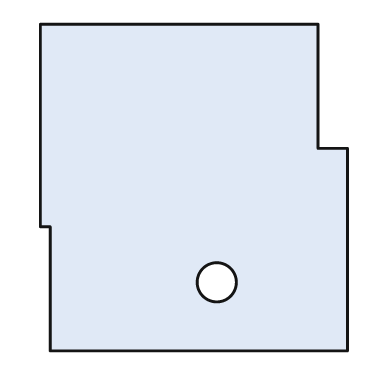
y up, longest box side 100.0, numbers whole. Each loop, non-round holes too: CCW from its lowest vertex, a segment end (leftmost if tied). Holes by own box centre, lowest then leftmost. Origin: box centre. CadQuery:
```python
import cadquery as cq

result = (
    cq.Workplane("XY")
    .moveTo(-44.0, -50.0)
    .lineTo(47.0, -50.0)
    .lineTo(47.0, 12.0)
    .lineTo(38.0, 12.0)
    .lineTo(38.0, 50.0)
    .lineTo(-47.0, 50.0)
    .lineTo(-47.0, -12.0)
    .lineTo(-44.0, -12.0)
    .close()
    .moveTo(7.0, -29.0)
    .circle(6.0)
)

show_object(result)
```